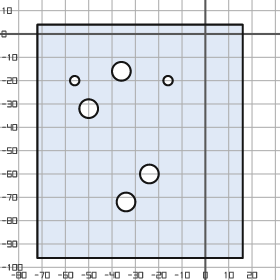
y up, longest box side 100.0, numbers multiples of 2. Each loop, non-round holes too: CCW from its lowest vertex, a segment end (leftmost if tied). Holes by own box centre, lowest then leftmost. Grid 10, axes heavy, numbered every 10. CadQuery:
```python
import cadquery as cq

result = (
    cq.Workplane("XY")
    .moveTo(-72.0, -96.0)
    .lineTo(16.0, -96.0)
    .lineTo(16.0, 4.0)
    .lineTo(-72.0, 4.0)
    .close()
    .moveTo(-34.0, -72.0)
    .circle(4.0)
    .moveTo(-24.0, -60.0)
    .circle(4.0)
    .moveTo(-50.0, -32.0)
    .circle(4.0)
    .moveTo(-56.0, -20.0)
    .circle(2.0)
    .moveTo(-16.0, -20.0)
    .circle(2.0)
    .moveTo(-36.0, -16.0)
    .circle(4.0)
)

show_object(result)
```